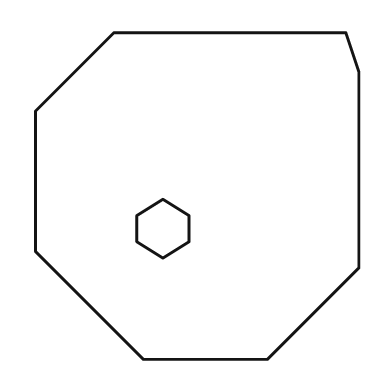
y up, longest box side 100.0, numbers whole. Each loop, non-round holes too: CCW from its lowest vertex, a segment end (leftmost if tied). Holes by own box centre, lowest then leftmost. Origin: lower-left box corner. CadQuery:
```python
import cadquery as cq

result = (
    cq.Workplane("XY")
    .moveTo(33.0, 0.0)
    .lineTo(71.0, 0.0)
    .lineTo(99.0, 28.0)
    .lineTo(99.0, 88.0)
    .lineTo(95.0, 100.0)
    .lineTo(24.0, 100.0)
    .lineTo(0.0, 76.0)
    .lineTo(0.0, 33.0)
    .close()
    .moveTo(39.0, 31.0)
    .lineTo(47.0, 36.0)
    .lineTo(47.0, 44.0)
    .lineTo(39.0, 49.0)
    .lineTo(31.0, 44.0)
    .lineTo(31.0, 36.0)
    .close()
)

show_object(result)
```